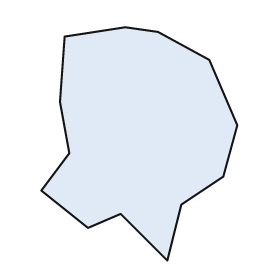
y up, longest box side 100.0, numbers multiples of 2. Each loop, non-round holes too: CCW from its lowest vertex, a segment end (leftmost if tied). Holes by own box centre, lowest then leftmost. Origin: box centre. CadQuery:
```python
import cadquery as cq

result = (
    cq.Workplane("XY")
    .moveTo(12.0, -50.0)
    .lineTo(18.0, -26.0)
    .lineTo(36.0, -14.0)
    .lineTo(42.0, 8.0)
    .lineTo(30.0, 36.0)
    .lineTo(8.0, 48.0)
    .lineTo(-6.0, 50.0)
    .lineTo(-32.0, 46.0)
    .lineTo(-34.0, 18.0)
    .lineTo(-30.0, -4.0)
    .lineTo(-42.0, -20.0)
    .lineTo(-22.0, -36.0)
    .lineTo(-8.0, -30.0)
    .close()
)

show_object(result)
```